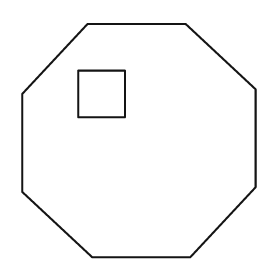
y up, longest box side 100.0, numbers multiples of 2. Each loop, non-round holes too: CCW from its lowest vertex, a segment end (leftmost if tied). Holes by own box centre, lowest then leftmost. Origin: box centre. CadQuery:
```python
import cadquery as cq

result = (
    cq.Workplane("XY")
    .moveTo(-20.0, -50.0)
    .lineTo(22.0, -50.0)
    .lineTo(50.0, -20.0)
    .lineTo(50.0, 22.0)
    .lineTo(20.0, 50.0)
    .lineTo(-22.0, 50.0)
    .lineTo(-50.0, 20.0)
    .lineTo(-50.0, -22.0)
    .close()
    .moveTo(-26.0, 10.0)
    .lineTo(-6.0, 10.0)
    .lineTo(-6.0, 30.0)
    .lineTo(-26.0, 30.0)
    .close()
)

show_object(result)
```